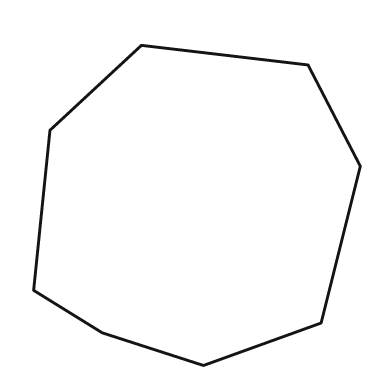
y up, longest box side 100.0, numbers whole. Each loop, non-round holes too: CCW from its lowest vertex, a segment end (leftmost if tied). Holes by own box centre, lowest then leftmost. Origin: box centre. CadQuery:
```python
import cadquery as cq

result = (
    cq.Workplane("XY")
    .moveTo(2.0, -49.0)
    .lineTo(38.0, -36.0)
    .lineTo(50.0, 12.0)
    .lineTo(34.0, 43.0)
    .lineTo(-17.0, 49.0)
    .lineTo(-45.0, 23.0)
    .lineTo(-50.0, -26.0)
    .lineTo(-29.0, -39.0)
    .close()
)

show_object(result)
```